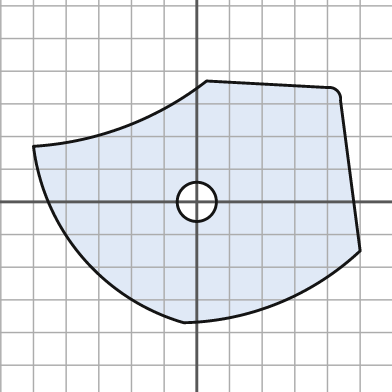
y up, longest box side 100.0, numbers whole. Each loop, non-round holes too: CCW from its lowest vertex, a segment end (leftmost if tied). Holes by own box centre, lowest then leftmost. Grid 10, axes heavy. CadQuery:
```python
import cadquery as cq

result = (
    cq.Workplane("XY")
    .moveTo(-4.0, -37.0)
    .threePointArc((25.0, -31.0), (50.0, -15.0))
    .lineTo(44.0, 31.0)
    .threePointArc((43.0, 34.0), (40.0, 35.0))
    .lineTo(3.0, 37.0)
    .threePointArc((-22.0, 23.0), (-50.0, 17.0))
    .threePointArc((-35.0, -17.0), (-4.0, -37.0))
    .close()
    .moveTo(0.0, 0.0)
    .circle(6.0)
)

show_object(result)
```